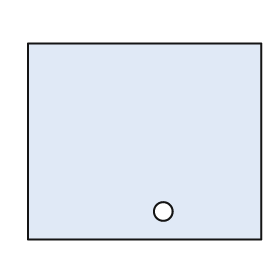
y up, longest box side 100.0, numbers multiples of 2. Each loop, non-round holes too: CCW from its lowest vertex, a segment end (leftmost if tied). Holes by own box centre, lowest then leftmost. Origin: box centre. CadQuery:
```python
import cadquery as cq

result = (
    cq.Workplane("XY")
    .moveTo(-50.0, -42.0)
    .lineTo(50.0, -42.0)
    .lineTo(50.0, 42.0)
    .lineTo(-50.0, 42.0)
    .close()
    .moveTo(8.0, -30.0)
    .circle(4.0)
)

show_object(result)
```